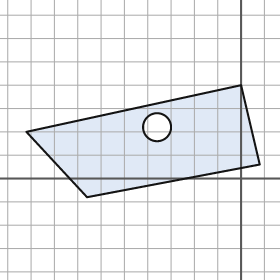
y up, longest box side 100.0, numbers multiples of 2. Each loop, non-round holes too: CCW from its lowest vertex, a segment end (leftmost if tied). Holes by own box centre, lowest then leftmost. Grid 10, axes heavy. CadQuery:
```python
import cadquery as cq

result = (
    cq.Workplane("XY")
    .moveTo(-66.0, -8.0)
    .lineTo(8.0, 6.0)
    .lineTo(0.0, 40.0)
    .lineTo(-92.0, 20.0)
    .close()
    .moveTo(-36.0, 22.0)
    .circle(6.0)
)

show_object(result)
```